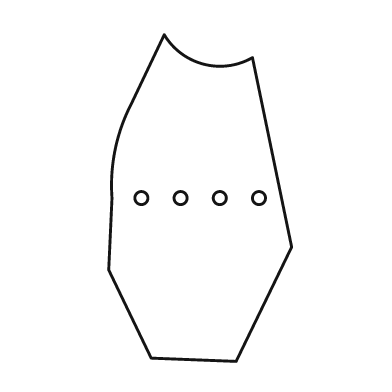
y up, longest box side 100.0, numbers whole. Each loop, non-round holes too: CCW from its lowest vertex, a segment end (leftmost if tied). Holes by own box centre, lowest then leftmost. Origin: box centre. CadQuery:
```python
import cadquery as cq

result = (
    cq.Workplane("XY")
    .moveTo(11.0, -50.0)
    .lineTo(28.0, -15.0)
    .lineTo(16.0, 43.0)
    .threePointArc((1.0, 41.0), (-11.0, 50.0))
    .lineTo(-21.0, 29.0)
    .threePointArc((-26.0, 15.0), (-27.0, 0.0))
    .lineTo(-28.0, -22.0)
    .lineTo(-15.0, -49.0)
    .close()
    .moveTo(-18.0, 0.0)
    .circle(2.0)
    .moveTo(-6.0, 0.0)
    .circle(2.0)
    .moveTo(6.0, 0.0)
    .circle(2.0)
    .moveTo(18.0, 0.0)
    .circle(2.0)
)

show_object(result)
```